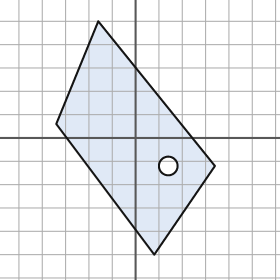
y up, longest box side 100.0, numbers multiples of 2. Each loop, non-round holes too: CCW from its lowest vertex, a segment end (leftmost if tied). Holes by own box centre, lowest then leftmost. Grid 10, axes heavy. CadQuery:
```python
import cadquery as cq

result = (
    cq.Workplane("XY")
    .moveTo(8.0, -50.0)
    .lineTo(34.0, -12.0)
    .lineTo(-16.0, 50.0)
    .lineTo(-34.0, 6.0)
    .close()
    .moveTo(14.0, -12.0)
    .circle(4.0)
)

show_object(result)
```